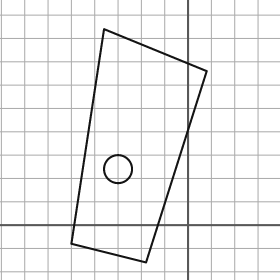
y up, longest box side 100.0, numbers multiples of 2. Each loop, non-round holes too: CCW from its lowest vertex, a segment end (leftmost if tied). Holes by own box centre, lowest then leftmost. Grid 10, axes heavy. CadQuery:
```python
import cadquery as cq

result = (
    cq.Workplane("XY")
    .moveTo(-18.0, -16.0)
    .lineTo(8.0, 66.0)
    .lineTo(-36.0, 84.0)
    .lineTo(-50.0, -8.0)
    .close()
    .moveTo(-30.0, 24.0)
    .circle(6.0)
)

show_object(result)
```